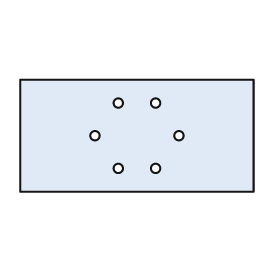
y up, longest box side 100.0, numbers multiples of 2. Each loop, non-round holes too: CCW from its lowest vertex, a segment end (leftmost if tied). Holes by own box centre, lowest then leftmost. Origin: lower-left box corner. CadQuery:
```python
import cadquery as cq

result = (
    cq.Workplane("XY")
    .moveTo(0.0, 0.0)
    .lineTo(100.0, 0.0)
    .lineTo(100.0, 48.0)
    .lineTo(0.0, 48.0)
    .close()
    .moveTo(42.0, 10.0)
    .circle(2.0)
    .moveTo(58.0, 10.0)
    .circle(2.0)
    .moveTo(32.0, 24.0)
    .circle(2.0)
    .moveTo(68.0, 24.0)
    .circle(2.0)
    .moveTo(42.0, 38.0)
    .circle(2.0)
    .moveTo(58.0, 38.0)
    .circle(2.0)
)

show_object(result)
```